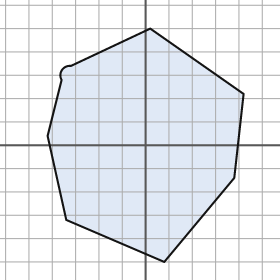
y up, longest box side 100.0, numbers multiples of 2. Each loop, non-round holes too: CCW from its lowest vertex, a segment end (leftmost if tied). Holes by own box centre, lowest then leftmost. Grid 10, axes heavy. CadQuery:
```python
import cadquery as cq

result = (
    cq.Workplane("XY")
    .moveTo(8.0, -50.0)
    .lineTo(38.0, -14.0)
    .lineTo(42.0, 22.0)
    .lineTo(2.0, 50.0)
    .lineTo(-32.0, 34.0)
    .threePointArc((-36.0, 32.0), (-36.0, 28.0))
    .lineTo(-42.0, 4.0)
    .lineTo(-34.0, -32.0)
    .close()
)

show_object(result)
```